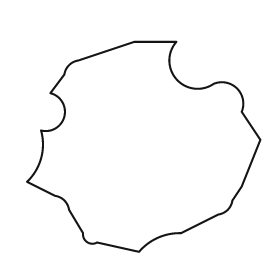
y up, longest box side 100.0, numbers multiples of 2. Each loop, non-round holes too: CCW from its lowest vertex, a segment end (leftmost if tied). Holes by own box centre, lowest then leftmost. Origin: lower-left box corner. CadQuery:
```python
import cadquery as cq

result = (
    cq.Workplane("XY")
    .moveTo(48.0, 0.0)
    .threePointArc((56.0, 6.0), (66.0, 8.0))
    .lineTo(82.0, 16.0)
    .threePointArc((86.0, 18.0), (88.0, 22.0))
    .lineTo(92.0, 28.0)
    .lineTo(100.0, 48.0)
    .lineTo(92.0, 60.0)
    .threePointArc((90.0, 70.0), (80.0, 72.0))
    .threePointArc((64.0, 74.0), (64.0, 90.0))
    .lineTo(46.0, 90.0)
    .lineTo(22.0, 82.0)
    .threePointArc((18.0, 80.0), (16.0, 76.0))
    .lineTo(10.0, 68.0)
    .threePointArc((16.0, 58.0), (6.0, 52.0))
    .threePointArc((6.0, 40.0), (0.0, 30.0))
    .lineTo(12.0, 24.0)
    .threePointArc((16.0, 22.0), (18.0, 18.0))
    .lineTo(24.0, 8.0)
    .threePointArc((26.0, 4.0), (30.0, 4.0))
    .close()
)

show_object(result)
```